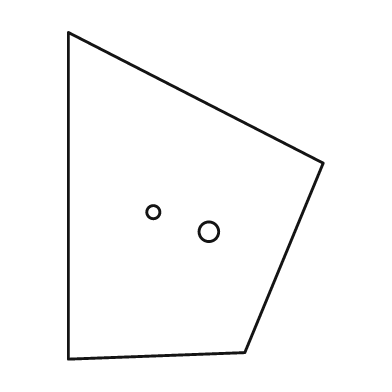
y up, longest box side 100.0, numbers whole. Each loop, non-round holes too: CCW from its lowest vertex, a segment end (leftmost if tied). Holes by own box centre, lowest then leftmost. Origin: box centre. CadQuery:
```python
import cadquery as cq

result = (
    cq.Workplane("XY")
    .moveTo(-39.0, -50.0)
    .lineTo(15.0, -48.0)
    .lineTo(39.0, 10.0)
    .lineTo(-39.0, 50.0)
    .close()
    .moveTo(4.0, -11.0)
    .circle(3.0)
    .moveTo(-13.0, -5.0)
    .circle(2.0)
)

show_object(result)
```